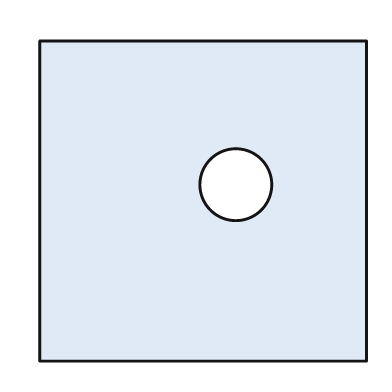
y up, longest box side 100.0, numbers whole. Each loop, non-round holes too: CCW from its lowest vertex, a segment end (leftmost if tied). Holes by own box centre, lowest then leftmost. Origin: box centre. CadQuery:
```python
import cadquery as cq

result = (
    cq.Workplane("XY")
    .moveTo(-50.0, -49.0)
    .lineTo(50.0, -49.0)
    .lineTo(50.0, 49.0)
    .lineTo(-50.0, 49.0)
    .close()
    .moveTo(10.0, 5.0)
    .circle(11.0)
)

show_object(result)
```